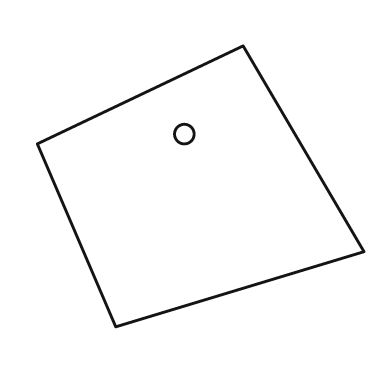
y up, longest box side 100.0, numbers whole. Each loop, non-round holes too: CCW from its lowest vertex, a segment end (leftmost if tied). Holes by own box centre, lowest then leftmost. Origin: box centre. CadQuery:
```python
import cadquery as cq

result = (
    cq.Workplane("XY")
    .moveTo(-26.0, -43.0)
    .lineTo(50.0, -20.0)
    .lineTo(13.0, 43.0)
    .lineTo(-50.0, 13.0)
    .close()
    .moveTo(-5.0, 16.0)
    .circle(3.0)
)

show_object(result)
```